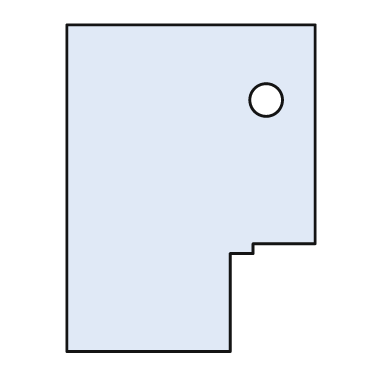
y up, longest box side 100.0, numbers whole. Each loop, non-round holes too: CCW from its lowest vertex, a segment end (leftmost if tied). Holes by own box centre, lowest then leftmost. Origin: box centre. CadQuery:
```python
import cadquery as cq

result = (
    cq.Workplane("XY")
    .moveTo(-38.0, -50.0)
    .lineTo(12.0, -50.0)
    .lineTo(12.0, -20.0)
    .lineTo(19.0, -20.0)
    .lineTo(19.0, -17.0)
    .lineTo(38.0, -17.0)
    .lineTo(38.0, 50.0)
    .lineTo(-38.0, 50.0)
    .close()
    .moveTo(23.0, 27.0)
    .circle(5.0)
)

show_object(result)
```